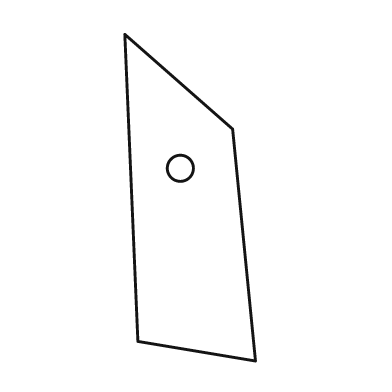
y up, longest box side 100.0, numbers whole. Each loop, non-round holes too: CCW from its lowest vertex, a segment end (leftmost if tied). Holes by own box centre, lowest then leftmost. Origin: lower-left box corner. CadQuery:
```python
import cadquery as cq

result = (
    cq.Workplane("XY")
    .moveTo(40.0, 0.0)
    .lineTo(33.0, 71.0)
    .lineTo(0.0, 100.0)
    .lineTo(4.0, 6.0)
    .close()
    .moveTo(17.0, 59.0)
    .circle(4.0)
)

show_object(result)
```